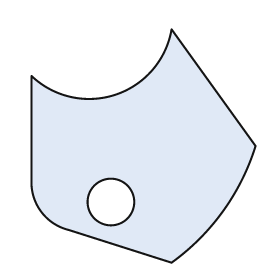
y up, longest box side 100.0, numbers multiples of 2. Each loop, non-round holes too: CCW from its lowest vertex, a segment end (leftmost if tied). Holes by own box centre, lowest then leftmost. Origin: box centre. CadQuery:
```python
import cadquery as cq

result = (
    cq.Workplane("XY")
    .moveTo(12.0, -50.0)
    .threePointArc((34.0, -28.0), (48.0, 0.0))
    .lineTo(12.0, 50.0)
    .threePointArc((-12.0, 22.0), (-48.0, 30.0))
    .lineTo(-48.0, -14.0)
    .threePointArc((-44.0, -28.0), (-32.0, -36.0))
    .close()
    .moveTo(-14.0, -24.0)
    .circle(10.0)
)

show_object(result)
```